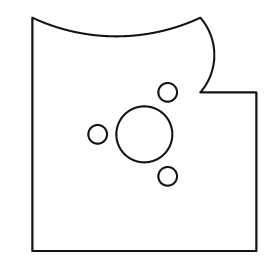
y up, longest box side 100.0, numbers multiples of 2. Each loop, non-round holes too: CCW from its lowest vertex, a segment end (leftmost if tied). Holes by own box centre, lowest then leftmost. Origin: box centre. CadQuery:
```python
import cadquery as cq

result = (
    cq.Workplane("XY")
    .moveTo(-48.0, -50.0)
    .lineTo(48.0, -50.0)
    .lineTo(48.0, 18.0)
    .lineTo(24.0, 18.0)
    .threePointArc((30.0, 34.0), (24.0, 50.0))
    .threePointArc((-12.0, 42.0), (-48.0, 50.0))
    .close()
    .moveTo(10.0, -18.0)
    .circle(4.0)
    .moveTo(-20.0, 0.0)
    .circle(4.0)
    .moveTo(0.0, 0.0)
    .circle(12.0)
    .moveTo(10.0, 18.0)
    .circle(4.0)
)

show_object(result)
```